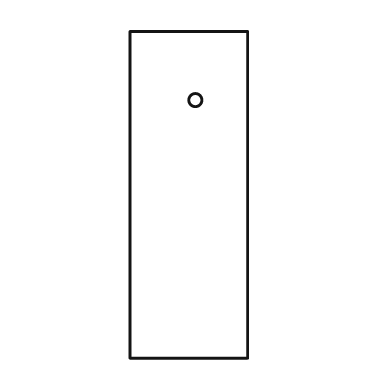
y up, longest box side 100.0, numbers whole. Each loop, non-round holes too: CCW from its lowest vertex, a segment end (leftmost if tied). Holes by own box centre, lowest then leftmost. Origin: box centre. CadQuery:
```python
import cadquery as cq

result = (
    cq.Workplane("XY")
    .moveTo(-18.0, -50.0)
    .lineTo(18.0, -50.0)
    .lineTo(18.0, 50.0)
    .lineTo(-18.0, 50.0)
    .close()
    .moveTo(2.0, 29.0)
    .circle(2.0)
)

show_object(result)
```